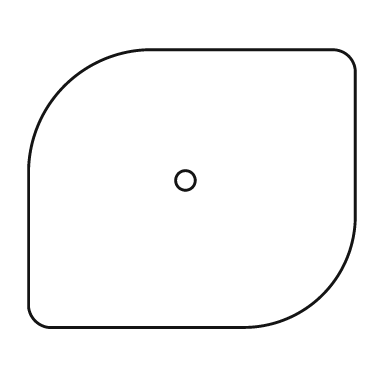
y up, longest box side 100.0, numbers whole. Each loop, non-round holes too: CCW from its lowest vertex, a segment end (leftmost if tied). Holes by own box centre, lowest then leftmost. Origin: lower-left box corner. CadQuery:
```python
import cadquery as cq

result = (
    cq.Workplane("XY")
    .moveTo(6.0, 0.0)
    .lineTo(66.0, 0.0)
    .threePointArc((90.0, 10.0), (100.0, 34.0))
    .lineTo(100.0, 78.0)
    .threePointArc((98.0, 83.0), (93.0, 85.0))
    .lineTo(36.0, 85.0)
    .threePointArc((11.0, 74.0), (0.0, 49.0))
    .lineTo(0.0, 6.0)
    .threePointArc((2.0, 2.0), (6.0, 0.0))
    .close()
    .moveTo(48.0, 45.0)
    .circle(3.0)
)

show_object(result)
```